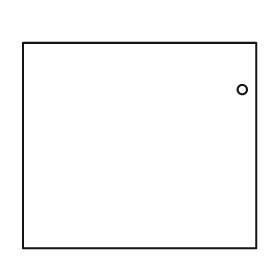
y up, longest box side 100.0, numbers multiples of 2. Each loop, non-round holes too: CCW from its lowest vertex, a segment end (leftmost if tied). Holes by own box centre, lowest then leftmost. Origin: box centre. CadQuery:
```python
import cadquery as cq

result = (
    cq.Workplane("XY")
    .moveTo(-50.0, -44.0)
    .lineTo(50.0, -44.0)
    .lineTo(50.0, 44.0)
    .lineTo(-50.0, 44.0)
    .close()
    .moveTo(44.0, 24.0)
    .circle(2.0)
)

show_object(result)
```